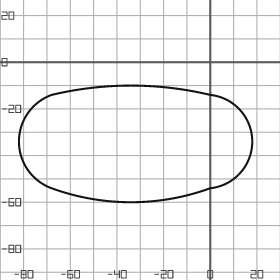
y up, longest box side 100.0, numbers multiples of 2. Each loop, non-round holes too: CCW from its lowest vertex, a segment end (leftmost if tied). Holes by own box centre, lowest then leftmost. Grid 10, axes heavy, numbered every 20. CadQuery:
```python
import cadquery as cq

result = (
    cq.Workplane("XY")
    .moveTo(-68.0, -54.0)
    .threePointArc((-34.0, -60.0), (0.0, -54.0))
    .threePointArc((18.0, -34.0), (0.0, -14.0))
    .threePointArc((-34.0, -10.0), (-68.0, -14.0))
    .threePointArc((-82.0, -34.0), (-68.0, -54.0))
    .close()
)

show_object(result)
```